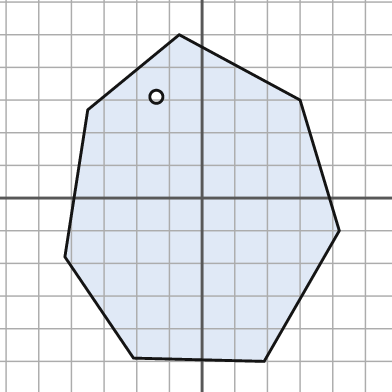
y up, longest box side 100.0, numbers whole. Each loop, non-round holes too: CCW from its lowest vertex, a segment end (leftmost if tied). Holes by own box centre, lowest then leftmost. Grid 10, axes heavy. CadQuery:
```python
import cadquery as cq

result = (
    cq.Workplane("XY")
    .moveTo(19.0, -50.0)
    .lineTo(42.0, -10.0)
    .lineTo(30.0, 30.0)
    .lineTo(-7.0, 50.0)
    .lineTo(-35.0, 27.0)
    .lineTo(-42.0, -18.0)
    .lineTo(-21.0, -49.0)
    .close()
    .moveTo(-14.0, 31.0)
    .circle(2.0)
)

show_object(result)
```